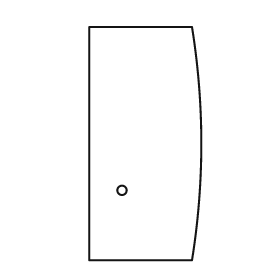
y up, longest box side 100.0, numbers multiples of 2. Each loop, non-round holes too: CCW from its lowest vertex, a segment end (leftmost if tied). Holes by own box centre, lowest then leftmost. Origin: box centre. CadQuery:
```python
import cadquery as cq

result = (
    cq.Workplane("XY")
    .moveTo(-24.0, -50.0)
    .lineTo(20.0, -50.0)
    .threePointArc((24.0, 0.0), (20.0, 50.0))
    .lineTo(-24.0, 50.0)
    .close()
    .moveTo(-10.0, -20.0)
    .circle(2.0)
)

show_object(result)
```